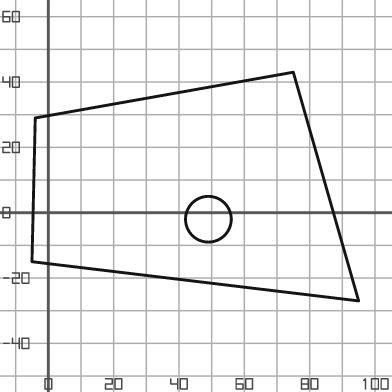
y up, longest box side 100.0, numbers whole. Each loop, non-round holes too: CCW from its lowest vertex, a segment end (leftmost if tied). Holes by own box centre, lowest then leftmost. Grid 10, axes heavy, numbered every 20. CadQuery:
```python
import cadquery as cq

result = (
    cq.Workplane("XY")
    .moveTo(95.0, -27.0)
    .lineTo(75.0, 43.0)
    .lineTo(-4.0, 29.0)
    .lineTo(-5.0, -15.0)
    .close()
    .moveTo(49.0, -2.0)
    .circle(7.0)
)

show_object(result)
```